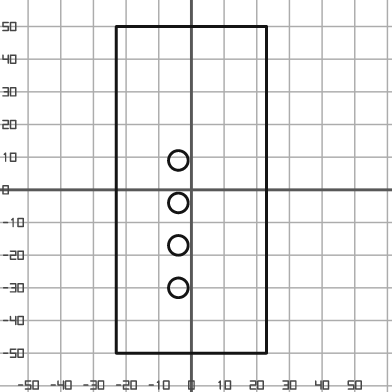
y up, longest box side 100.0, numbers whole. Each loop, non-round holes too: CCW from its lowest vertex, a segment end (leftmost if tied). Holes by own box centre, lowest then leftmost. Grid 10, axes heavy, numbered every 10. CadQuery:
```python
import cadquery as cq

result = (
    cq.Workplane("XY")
    .moveTo(-23.0, -50.0)
    .lineTo(23.0, -50.0)
    .lineTo(23.0, 50.0)
    .lineTo(-23.0, 50.0)
    .close()
    .moveTo(-4.0, -30.0)
    .circle(3.0)
    .moveTo(-4.0, -17.0)
    .circle(3.0)
    .moveTo(-4.0, -4.0)
    .circle(3.0)
    .moveTo(-4.0, 9.0)
    .circle(3.0)
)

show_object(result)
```